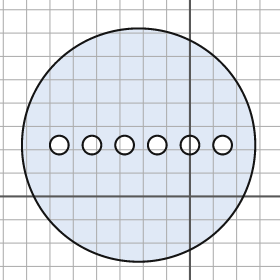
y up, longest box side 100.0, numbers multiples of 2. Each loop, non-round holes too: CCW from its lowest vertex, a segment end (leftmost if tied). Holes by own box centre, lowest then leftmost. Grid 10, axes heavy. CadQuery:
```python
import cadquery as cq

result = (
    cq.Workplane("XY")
    .moveTo(-22.0, 22.0)
    .circle(50.0)
    .moveTo(-56.0, 22.0)
    .circle(4.0)
    .moveTo(-42.0, 22.0)
    .circle(4.0)
    .moveTo(-28.0, 22.0)
    .circle(4.0)
    .moveTo(-14.0, 22.0)
    .circle(4.0)
    .moveTo(0.0, 22.0)
    .circle(4.0)
    .moveTo(14.0, 22.0)
    .circle(4.0)
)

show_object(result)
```